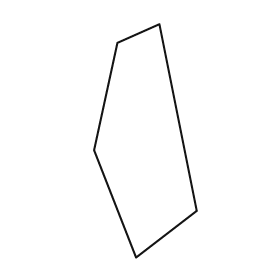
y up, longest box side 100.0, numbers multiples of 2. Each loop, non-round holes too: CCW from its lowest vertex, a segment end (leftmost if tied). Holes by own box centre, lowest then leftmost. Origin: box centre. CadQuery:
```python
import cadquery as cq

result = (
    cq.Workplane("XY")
    .moveTo(-4.0, -50.0)
    .lineTo(22.0, -30.0)
    .lineTo(6.0, 50.0)
    .lineTo(-12.0, 42.0)
    .lineTo(-22.0, -4.0)
    .close()
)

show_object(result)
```